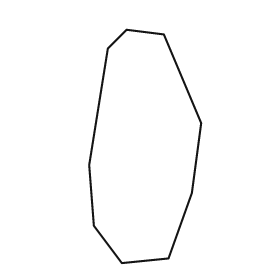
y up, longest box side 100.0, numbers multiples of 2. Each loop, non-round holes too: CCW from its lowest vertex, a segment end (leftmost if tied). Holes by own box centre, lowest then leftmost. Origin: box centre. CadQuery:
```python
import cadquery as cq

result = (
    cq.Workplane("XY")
    .moveTo(-10.0, -50.0)
    .lineTo(10.0, -48.0)
    .lineTo(20.0, -20.0)
    .lineTo(24.0, 10.0)
    .lineTo(8.0, 48.0)
    .lineTo(-8.0, 50.0)
    .lineTo(-16.0, 42.0)
    .lineTo(-24.0, -8.0)
    .lineTo(-22.0, -34.0)
    .close()
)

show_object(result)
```